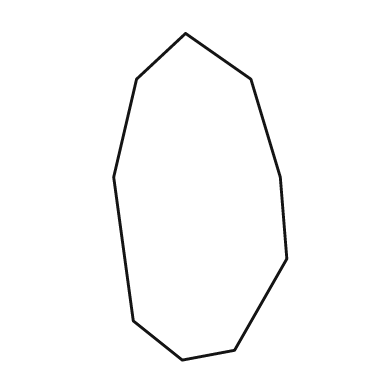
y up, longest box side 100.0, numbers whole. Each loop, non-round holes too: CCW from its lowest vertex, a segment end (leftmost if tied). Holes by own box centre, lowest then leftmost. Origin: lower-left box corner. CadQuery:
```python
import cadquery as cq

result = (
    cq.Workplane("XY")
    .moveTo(21.0, 0.0)
    .lineTo(37.0, 3.0)
    .lineTo(53.0, 31.0)
    .lineTo(51.0, 56.0)
    .lineTo(42.0, 86.0)
    .lineTo(22.0, 100.0)
    .lineTo(7.0, 86.0)
    .lineTo(0.0, 56.0)
    .lineTo(6.0, 12.0)
    .close()
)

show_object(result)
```